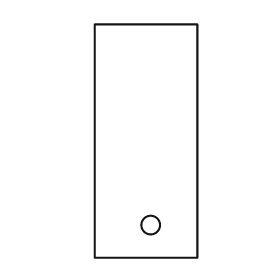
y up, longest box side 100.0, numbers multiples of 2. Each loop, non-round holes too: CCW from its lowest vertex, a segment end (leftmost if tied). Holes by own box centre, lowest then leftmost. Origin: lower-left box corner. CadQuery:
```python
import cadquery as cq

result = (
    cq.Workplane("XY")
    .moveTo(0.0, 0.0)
    .lineTo(44.0, 0.0)
    .lineTo(44.0, 100.0)
    .lineTo(0.0, 100.0)
    .close()
    .moveTo(24.0, 14.0)
    .circle(4.0)
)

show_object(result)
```